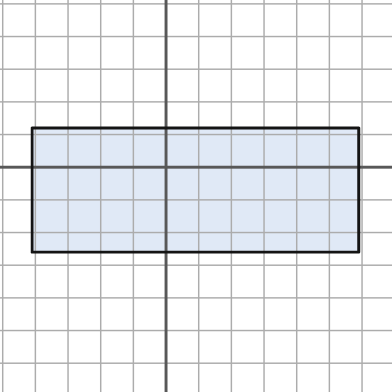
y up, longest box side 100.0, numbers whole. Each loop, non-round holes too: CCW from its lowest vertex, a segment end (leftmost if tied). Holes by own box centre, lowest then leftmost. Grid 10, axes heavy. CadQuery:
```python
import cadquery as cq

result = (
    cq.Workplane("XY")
    .moveTo(-41.0, -26.0)
    .lineTo(59.0, -26.0)
    .lineTo(59.0, 12.0)
    .lineTo(-41.0, 12.0)
    .close()
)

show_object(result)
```